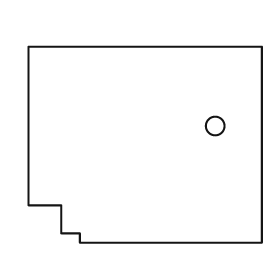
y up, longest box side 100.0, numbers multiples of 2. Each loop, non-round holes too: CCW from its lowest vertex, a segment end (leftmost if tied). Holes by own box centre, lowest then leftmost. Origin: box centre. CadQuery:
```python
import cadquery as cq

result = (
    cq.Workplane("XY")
    .moveTo(-28.0, -42.0)
    .lineTo(50.0, -42.0)
    .lineTo(50.0, 42.0)
    .lineTo(-50.0, 42.0)
    .lineTo(-50.0, -26.0)
    .lineTo(-36.0, -26.0)
    .lineTo(-36.0, -38.0)
    .lineTo(-28.0, -38.0)
    .close()
    .moveTo(30.0, 8.0)
    .circle(4.0)
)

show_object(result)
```